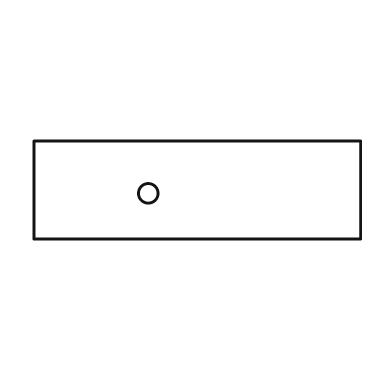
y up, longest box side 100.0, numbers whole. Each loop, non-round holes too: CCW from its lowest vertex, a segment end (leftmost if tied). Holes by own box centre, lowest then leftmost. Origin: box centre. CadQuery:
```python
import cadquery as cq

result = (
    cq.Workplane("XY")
    .moveTo(-50.0, -15.0)
    .lineTo(50.0, -15.0)
    .lineTo(50.0, 15.0)
    .lineTo(-50.0, 15.0)
    .close()
    .moveTo(-15.0, -1.0)
    .circle(3.0)
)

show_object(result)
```